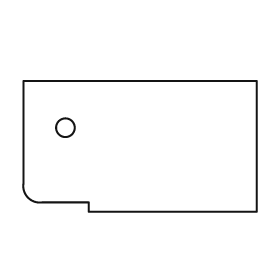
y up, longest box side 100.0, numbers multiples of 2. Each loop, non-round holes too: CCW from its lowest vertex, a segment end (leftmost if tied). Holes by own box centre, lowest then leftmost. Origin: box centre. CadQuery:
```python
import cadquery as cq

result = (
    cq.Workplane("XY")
    .moveTo(-22.0, -28.0)
    .lineTo(50.0, -28.0)
    .lineTo(50.0, 28.0)
    .lineTo(-50.0, 28.0)
    .lineTo(-50.0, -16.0)
    .threePointArc((-48.0, -22.0), (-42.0, -24.0))
    .lineTo(-22.0, -24.0)
    .close()
    .moveTo(-32.0, 8.0)
    .circle(4.0)
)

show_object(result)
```